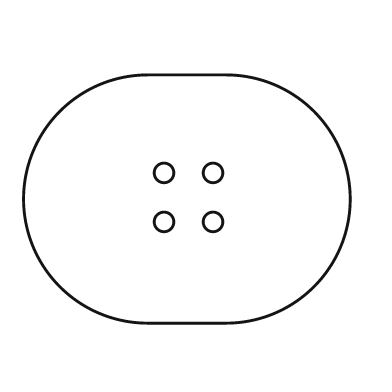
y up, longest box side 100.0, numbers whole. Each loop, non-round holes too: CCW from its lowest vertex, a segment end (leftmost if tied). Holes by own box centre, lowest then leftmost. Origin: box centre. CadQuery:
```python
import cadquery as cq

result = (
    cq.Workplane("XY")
    .moveTo(-12.0, -38.0)
    .lineTo(12.0, -38.0)
    .threePointArc((50.0, 0.0), (12.0, 38.0))
    .lineTo(-12.0, 38.0)
    .threePointArc((-50.0, 0.0), (-12.0, -38.0))
    .close()
    .moveTo(-7.0, -7.0)
    .circle(3.0)
    .moveTo(8.0, -7.0)
    .circle(3.0)
    .moveTo(-7.0, 8.0)
    .circle(3.0)
    .moveTo(8.0, 8.0)
    .circle(3.0)
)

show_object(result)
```